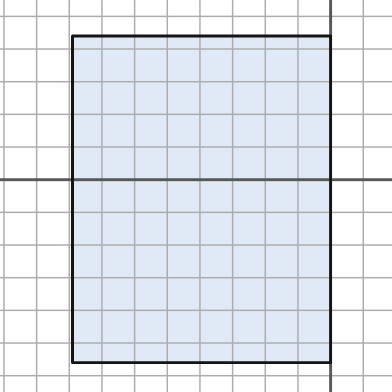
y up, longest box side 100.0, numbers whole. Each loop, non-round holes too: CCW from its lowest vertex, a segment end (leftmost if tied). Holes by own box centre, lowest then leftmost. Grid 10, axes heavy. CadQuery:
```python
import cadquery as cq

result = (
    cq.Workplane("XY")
    .moveTo(-79.0, -56.0)
    .lineTo(0.0, -56.0)
    .lineTo(0.0, 44.0)
    .lineTo(-79.0, 44.0)
    .close()
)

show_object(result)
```